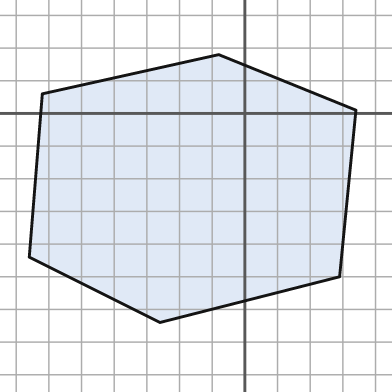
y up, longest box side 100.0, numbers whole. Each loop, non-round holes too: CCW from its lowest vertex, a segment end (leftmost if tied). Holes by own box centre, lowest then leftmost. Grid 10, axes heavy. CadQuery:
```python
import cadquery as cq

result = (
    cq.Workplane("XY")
    .moveTo(-26.0, -64.0)
    .lineTo(29.0, -50.0)
    .lineTo(34.0, 1.0)
    .lineTo(-8.0, 18.0)
    .lineTo(-62.0, 6.0)
    .lineTo(-66.0, -44.0)
    .close()
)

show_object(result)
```